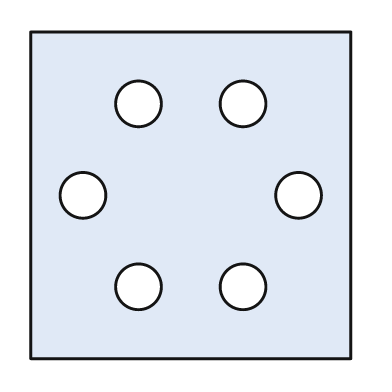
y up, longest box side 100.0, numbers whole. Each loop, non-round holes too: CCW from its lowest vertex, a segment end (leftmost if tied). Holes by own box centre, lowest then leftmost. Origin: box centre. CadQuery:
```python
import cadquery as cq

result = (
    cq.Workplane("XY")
    .moveTo(-49.0, -50.0)
    .lineTo(49.0, -50.0)
    .lineTo(49.0, 50.0)
    .lineTo(-49.0, 50.0)
    .close()
    .moveTo(-16.0, -28.0)
    .circle(7.0)
    .moveTo(16.0, -28.0)
    .circle(7.0)
    .moveTo(-33.0, 0.0)
    .circle(7.0)
    .moveTo(33.0, 0.0)
    .circle(7.0)
    .moveTo(-16.0, 28.0)
    .circle(7.0)
    .moveTo(16.0, 28.0)
    .circle(7.0)
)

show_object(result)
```